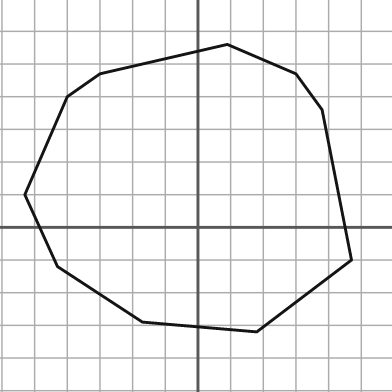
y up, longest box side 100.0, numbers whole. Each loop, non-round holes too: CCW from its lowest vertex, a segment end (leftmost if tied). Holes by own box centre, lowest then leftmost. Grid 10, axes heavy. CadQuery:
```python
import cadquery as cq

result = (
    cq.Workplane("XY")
    .moveTo(18.0, -32.0)
    .lineTo(47.0, -10.0)
    .lineTo(38.0, 36.0)
    .lineTo(30.0, 47.0)
    .lineTo(9.0, 56.0)
    .lineTo(-30.0, 47.0)
    .lineTo(-40.0, 40.0)
    .lineTo(-53.0, 10.0)
    .lineTo(-43.0, -12.0)
    .lineTo(-17.0, -29.0)
    .close()
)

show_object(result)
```